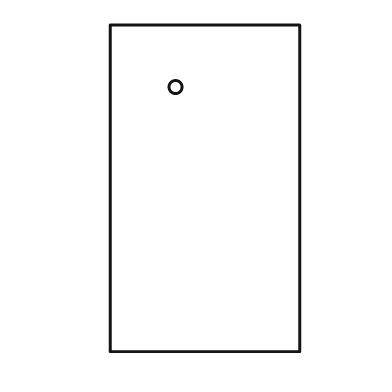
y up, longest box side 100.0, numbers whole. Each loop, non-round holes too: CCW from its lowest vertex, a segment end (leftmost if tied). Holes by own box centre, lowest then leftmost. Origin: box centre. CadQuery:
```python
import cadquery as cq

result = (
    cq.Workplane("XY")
    .moveTo(-29.0, -50.0)
    .lineTo(29.0, -50.0)
    .lineTo(29.0, 50.0)
    .lineTo(-29.0, 50.0)
    .close()
    .moveTo(-9.0, 31.0)
    .circle(2.0)
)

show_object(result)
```